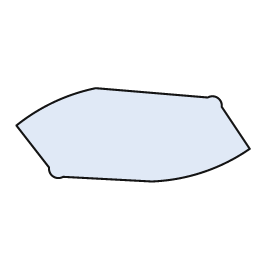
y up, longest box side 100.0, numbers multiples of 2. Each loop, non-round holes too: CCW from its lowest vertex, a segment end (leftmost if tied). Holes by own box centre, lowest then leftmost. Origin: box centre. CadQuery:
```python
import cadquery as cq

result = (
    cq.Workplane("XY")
    .moveTo(8.0, -20.0)
    .threePointArc((30.0, -16.0), (50.0, -6.0))
    .lineTo(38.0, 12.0)
    .threePointArc((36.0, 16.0), (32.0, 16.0))
    .lineTo(-16.0, 20.0)
    .threePointArc((-34.0, 14.0), (-50.0, 4.0))
    .lineTo(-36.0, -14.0)
    .threePointArc((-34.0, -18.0), (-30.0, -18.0))
    .close()
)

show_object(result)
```